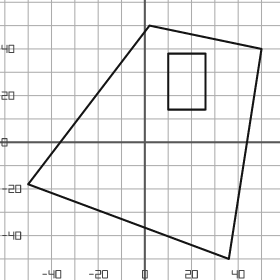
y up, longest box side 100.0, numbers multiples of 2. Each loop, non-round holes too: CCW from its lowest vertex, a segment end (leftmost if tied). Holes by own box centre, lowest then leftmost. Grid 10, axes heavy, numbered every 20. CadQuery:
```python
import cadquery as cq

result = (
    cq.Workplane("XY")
    .moveTo(36.0, -50.0)
    .lineTo(50.0, 40.0)
    .lineTo(2.0, 50.0)
    .lineTo(-50.0, -18.0)
    .close()
    .moveTo(10.0, 14.0)
    .lineTo(26.0, 14.0)
    .lineTo(26.0, 38.0)
    .lineTo(10.0, 38.0)
    .close()
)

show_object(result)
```